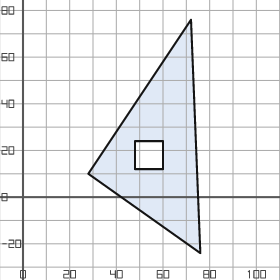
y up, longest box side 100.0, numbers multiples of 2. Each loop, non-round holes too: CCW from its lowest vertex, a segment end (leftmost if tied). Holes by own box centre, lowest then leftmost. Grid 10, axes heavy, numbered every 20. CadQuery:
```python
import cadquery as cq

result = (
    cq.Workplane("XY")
    .moveTo(76.0, -24.0)
    .lineTo(72.0, 76.0)
    .lineTo(28.0, 10.0)
    .close()
    .moveTo(48.0, 12.0)
    .lineTo(60.0, 12.0)
    .lineTo(60.0, 24.0)
    .lineTo(48.0, 24.0)
    .close()
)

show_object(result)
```